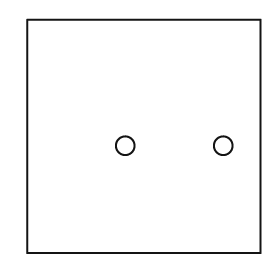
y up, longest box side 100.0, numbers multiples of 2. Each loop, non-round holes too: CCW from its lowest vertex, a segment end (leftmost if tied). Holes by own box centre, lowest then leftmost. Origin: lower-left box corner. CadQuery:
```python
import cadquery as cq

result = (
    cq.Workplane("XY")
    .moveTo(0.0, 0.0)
    .lineTo(100.0, 0.0)
    .lineTo(100.0, 100.0)
    .lineTo(0.0, 100.0)
    .close()
    .moveTo(42.0, 46.0)
    .circle(4.0)
    .moveTo(84.0, 46.0)
    .circle(4.0)
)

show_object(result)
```